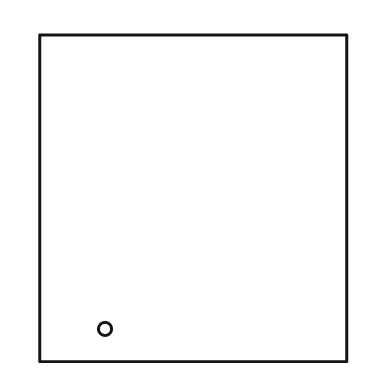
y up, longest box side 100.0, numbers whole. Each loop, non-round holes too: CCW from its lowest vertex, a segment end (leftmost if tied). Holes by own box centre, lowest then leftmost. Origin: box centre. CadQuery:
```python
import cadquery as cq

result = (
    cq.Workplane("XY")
    .moveTo(-47.0, -50.0)
    .lineTo(47.0, -50.0)
    .lineTo(47.0, 50.0)
    .lineTo(-47.0, 50.0)
    .close()
    .moveTo(-27.0, -40.0)
    .circle(2.0)
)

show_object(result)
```